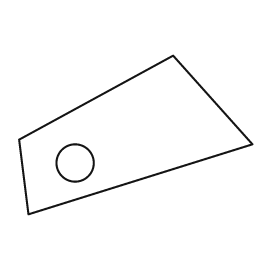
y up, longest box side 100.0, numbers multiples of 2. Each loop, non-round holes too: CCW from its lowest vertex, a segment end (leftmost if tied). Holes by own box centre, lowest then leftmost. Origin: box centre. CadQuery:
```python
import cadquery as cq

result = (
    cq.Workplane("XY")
    .moveTo(-46.0, -34.0)
    .lineTo(50.0, -4.0)
    .lineTo(16.0, 34.0)
    .lineTo(-50.0, -2.0)
    .close()
    .moveTo(-26.0, -12.0)
    .circle(8.0)
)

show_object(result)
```